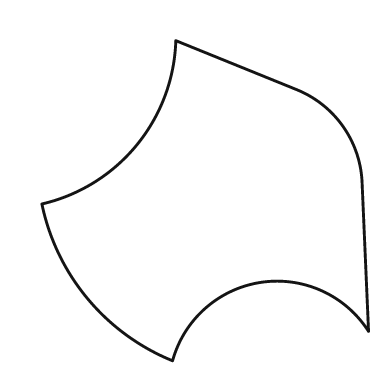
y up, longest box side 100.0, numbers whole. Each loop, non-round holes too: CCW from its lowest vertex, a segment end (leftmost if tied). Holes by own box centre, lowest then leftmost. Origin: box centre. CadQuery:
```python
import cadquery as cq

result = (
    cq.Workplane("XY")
    .moveTo(-10.0, -49.0)
    .threePointArc((17.0, -25.0), (50.0, -40.0))
    .lineTo(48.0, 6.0)
    .threePointArc((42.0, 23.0), (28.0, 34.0))
    .lineTo(-9.0, 49.0)
    .threePointArc((-21.0, 17.0), (-50.0, -1.0))
    .threePointArc((-36.0, -30.0), (-10.0, -49.0))
    .close()
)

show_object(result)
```